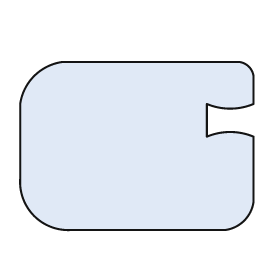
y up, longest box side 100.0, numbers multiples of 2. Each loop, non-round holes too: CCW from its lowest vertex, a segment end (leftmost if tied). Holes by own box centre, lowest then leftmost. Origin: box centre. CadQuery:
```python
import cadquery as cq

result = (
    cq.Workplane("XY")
    .moveTo(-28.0, -36.0)
    .lineTo(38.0, -36.0)
    .threePointArc((46.0, -32.0), (50.0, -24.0))
    .lineTo(50.0, 4.0)
    .threePointArc((40.0, 6.0), (30.0, 4.0))
    .lineTo(30.0, 18.0)
    .threePointArc((40.0, 16.0), (50.0, 18.0))
    .lineTo(50.0, 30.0)
    .threePointArc((48.0, 34.0), (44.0, 36.0))
    .lineTo(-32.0, 36.0)
    .threePointArc((-44.0, 30.0), (-50.0, 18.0))
    .lineTo(-50.0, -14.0)
    .threePointArc((-44.0, -30.0), (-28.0, -36.0))
    .close()
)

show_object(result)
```